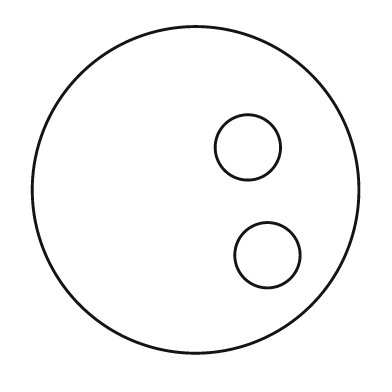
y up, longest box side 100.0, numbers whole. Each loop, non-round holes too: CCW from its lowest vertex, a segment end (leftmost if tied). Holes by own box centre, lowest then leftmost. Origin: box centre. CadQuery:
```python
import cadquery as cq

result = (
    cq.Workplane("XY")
    .moveTo(0.0, 0.0)
    .circle(50.0)
    .moveTo(22.0, -20.0)
    .circle(10.0)
    .moveTo(16.0, 13.0)
    .circle(10.0)
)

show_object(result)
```